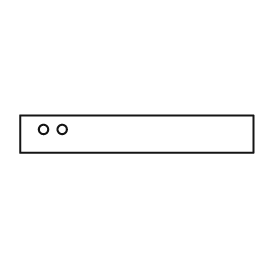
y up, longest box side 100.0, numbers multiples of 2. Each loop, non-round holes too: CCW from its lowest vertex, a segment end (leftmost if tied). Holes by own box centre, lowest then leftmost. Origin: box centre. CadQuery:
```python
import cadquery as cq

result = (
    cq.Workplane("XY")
    .moveTo(-50.0, -8.0)
    .lineTo(50.0, -8.0)
    .lineTo(50.0, 8.0)
    .lineTo(-50.0, 8.0)
    .close()
    .moveTo(-40.0, 2.0)
    .circle(2.0)
    .moveTo(-32.0, 2.0)
    .circle(2.0)
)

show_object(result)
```